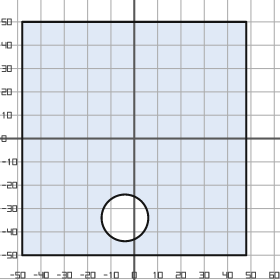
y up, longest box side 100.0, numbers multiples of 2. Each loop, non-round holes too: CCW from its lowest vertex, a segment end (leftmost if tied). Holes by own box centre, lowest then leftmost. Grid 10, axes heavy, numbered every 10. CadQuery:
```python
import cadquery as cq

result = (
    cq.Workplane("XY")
    .moveTo(-48.0, -50.0)
    .lineTo(48.0, -50.0)
    .lineTo(48.0, 50.0)
    .lineTo(-48.0, 50.0)
    .close()
    .moveTo(-4.0, -34.0)
    .circle(10.0)
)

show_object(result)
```